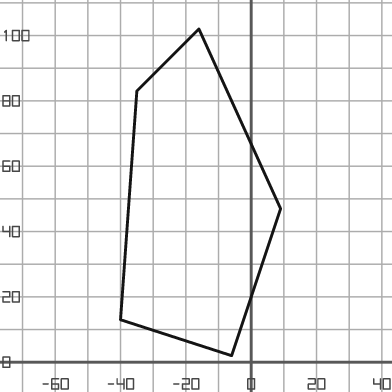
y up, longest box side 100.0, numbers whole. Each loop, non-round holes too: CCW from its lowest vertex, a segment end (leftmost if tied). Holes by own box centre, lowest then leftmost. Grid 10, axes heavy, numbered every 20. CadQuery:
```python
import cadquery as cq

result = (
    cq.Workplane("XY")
    .moveTo(-6.0, 2.0)
    .lineTo(9.0, 47.0)
    .lineTo(-16.0, 102.0)
    .lineTo(-35.0, 83.0)
    .lineTo(-40.0, 13.0)
    .close()
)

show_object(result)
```